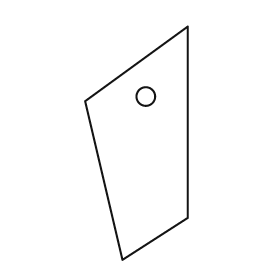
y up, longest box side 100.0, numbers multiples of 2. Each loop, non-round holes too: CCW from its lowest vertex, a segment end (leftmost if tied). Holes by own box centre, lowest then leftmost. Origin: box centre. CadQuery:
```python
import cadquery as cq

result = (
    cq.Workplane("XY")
    .moveTo(-6.0, -50.0)
    .lineTo(22.0, -32.0)
    .lineTo(22.0, 50.0)
    .lineTo(-22.0, 18.0)
    .close()
    .moveTo(4.0, 20.0)
    .circle(4.0)
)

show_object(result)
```